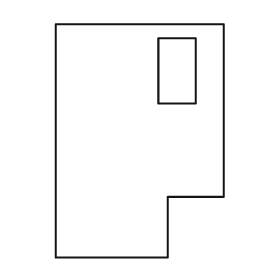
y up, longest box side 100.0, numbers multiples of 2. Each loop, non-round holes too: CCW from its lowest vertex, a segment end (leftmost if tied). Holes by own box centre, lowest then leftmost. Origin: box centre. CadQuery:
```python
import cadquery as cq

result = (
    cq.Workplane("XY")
    .moveTo(-36.0, -50.0)
    .lineTo(12.0, -50.0)
    .lineTo(12.0, -24.0)
    .lineTo(36.0, -24.0)
    .lineTo(36.0, 50.0)
    .lineTo(-36.0, 50.0)
    .close()
    .moveTo(8.0, 16.0)
    .lineTo(24.0, 16.0)
    .lineTo(24.0, 44.0)
    .lineTo(8.0, 44.0)
    .close()
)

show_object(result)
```